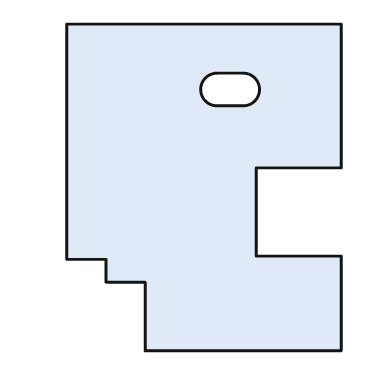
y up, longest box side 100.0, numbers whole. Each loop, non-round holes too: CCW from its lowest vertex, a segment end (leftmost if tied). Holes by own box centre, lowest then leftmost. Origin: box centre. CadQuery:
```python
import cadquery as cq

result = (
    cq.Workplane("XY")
    .moveTo(-18.0, -50.0)
    .lineTo(42.0, -50.0)
    .lineTo(42.0, -21.0)
    .lineTo(16.0, -21.0)
    .lineTo(16.0, 6.0)
    .lineTo(42.0, 6.0)
    .lineTo(42.0, 50.0)
    .lineTo(-42.0, 50.0)
    .lineTo(-42.0, -22.0)
    .lineTo(-30.0, -22.0)
    .lineTo(-30.0, -29.0)
    .lineTo(-18.0, -29.0)
    .close()
    .moveTo(4.0, 25.0)
    .lineTo(12.0, 25.0)
    .threePointArc((17.0, 30.0), (12.0, 35.0))
    .lineTo(4.0, 35.0)
    .threePointArc((-1.0, 30.0), (4.0, 25.0))
    .close()
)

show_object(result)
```